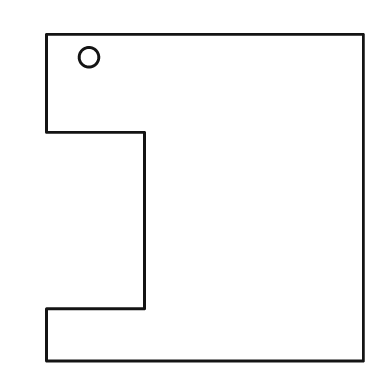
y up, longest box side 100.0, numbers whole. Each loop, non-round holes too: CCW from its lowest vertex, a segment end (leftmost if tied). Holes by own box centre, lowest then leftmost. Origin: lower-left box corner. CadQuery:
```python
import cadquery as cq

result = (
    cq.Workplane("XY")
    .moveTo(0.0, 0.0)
    .lineTo(97.0, 0.0)
    .lineTo(97.0, 100.0)
    .lineTo(0.0, 100.0)
    .lineTo(0.0, 70.0)
    .lineTo(30.0, 70.0)
    .lineTo(30.0, 16.0)
    .lineTo(0.0, 16.0)
    .close()
    .moveTo(13.0, 93.0)
    .circle(3.0)
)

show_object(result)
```